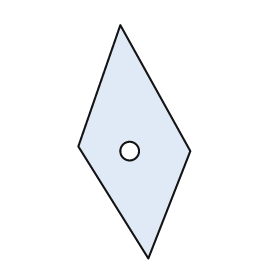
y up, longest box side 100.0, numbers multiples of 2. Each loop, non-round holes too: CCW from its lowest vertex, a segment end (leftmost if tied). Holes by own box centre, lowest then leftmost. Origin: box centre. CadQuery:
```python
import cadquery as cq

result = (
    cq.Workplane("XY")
    .moveTo(6.0, -50.0)
    .lineTo(24.0, -4.0)
    .lineTo(-6.0, 50.0)
    .lineTo(-24.0, -2.0)
    .close()
    .moveTo(-2.0, -4.0)
    .circle(4.0)
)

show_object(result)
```